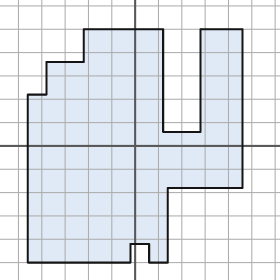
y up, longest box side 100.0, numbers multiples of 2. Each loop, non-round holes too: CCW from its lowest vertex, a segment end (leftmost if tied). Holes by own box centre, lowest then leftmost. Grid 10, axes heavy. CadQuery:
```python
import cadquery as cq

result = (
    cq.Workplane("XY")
    .moveTo(-46.0, -50.0)
    .lineTo(-2.0, -50.0)
    .lineTo(-2.0, -42.0)
    .lineTo(6.0, -42.0)
    .lineTo(6.0, -50.0)
    .lineTo(14.0, -50.0)
    .lineTo(14.0, -18.0)
    .lineTo(46.0, -18.0)
    .lineTo(46.0, 50.0)
    .lineTo(28.0, 50.0)
    .lineTo(28.0, 6.0)
    .lineTo(12.0, 6.0)
    .lineTo(12.0, 50.0)
    .lineTo(-22.0, 50.0)
    .lineTo(-22.0, 36.0)
    .lineTo(-38.0, 36.0)
    .lineTo(-38.0, 22.0)
    .lineTo(-46.0, 22.0)
    .close()
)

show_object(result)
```